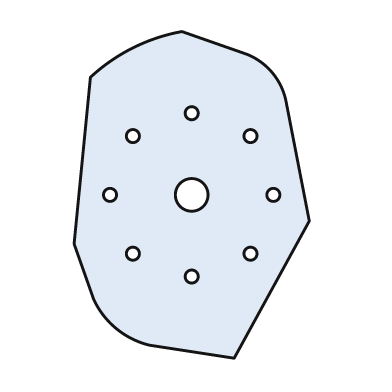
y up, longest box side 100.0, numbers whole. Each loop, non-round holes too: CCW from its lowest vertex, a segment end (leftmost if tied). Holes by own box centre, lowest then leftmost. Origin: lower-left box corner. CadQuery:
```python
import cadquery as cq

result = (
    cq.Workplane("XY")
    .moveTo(49.0, 0.0)
    .lineTo(72.0, 42.0)
    .lineTo(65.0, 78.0)
    .threePointArc((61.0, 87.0), (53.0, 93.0))
    .lineTo(33.0, 100.0)
    .threePointArc((18.0, 95.0), (5.0, 86.0))
    .lineTo(0.0, 35.0)
    .lineTo(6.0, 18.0)
    .threePointArc((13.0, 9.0), (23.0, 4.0))
    .close()
    .moveTo(36.0, 25.0)
    .circle(2.0)
    .moveTo(18.0, 32.0)
    .circle(2.0)
    .moveTo(54.0, 32.0)
    .circle(2.0)
    .moveTo(11.0, 50.0)
    .circle(2.0)
    .moveTo(36.0, 50.0)
    .circle(5.0)
    .moveTo(61.0, 50.0)
    .circle(2.0)
    .moveTo(18.0, 68.0)
    .circle(2.0)
    .moveTo(54.0, 68.0)
    .circle(2.0)
    .moveTo(36.0, 75.0)
    .circle(2.0)
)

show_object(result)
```